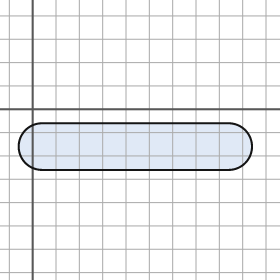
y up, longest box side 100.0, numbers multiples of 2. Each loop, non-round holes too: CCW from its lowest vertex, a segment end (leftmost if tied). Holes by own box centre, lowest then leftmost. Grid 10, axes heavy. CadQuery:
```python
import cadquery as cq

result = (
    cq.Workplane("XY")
    .moveTo(4.0, -26.0)
    .lineTo(84.0, -26.0)
    .threePointArc((94.0, -16.0), (84.0, -6.0))
    .lineTo(4.0, -6.0)
    .threePointArc((-6.0, -16.0), (4.0, -26.0))
    .close()
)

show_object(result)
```